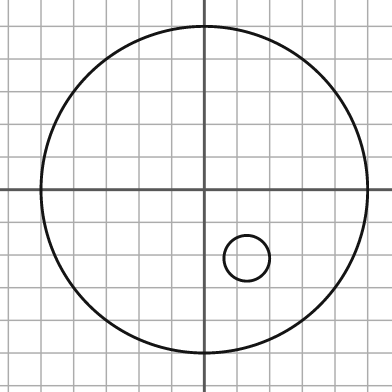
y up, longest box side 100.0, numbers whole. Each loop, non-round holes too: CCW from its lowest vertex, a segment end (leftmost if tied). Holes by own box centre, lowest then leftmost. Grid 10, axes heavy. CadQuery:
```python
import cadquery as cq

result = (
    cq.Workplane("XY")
    .moveTo(0.0, 0.0)
    .circle(50.0)
    .moveTo(13.0, -21.0)
    .circle(7.0)
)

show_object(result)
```